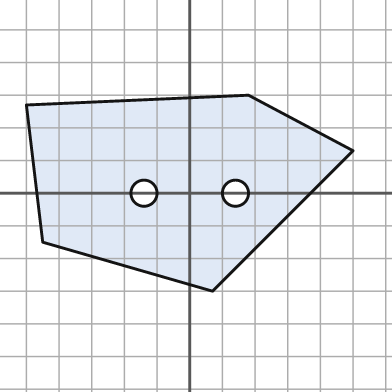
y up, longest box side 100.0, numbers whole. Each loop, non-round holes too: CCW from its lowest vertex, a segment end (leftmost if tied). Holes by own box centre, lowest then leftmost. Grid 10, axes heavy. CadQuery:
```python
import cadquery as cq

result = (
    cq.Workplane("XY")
    .moveTo(7.0, -30.0)
    .lineTo(50.0, 13.0)
    .lineTo(18.0, 30.0)
    .lineTo(-50.0, 27.0)
    .lineTo(-45.0, -15.0)
    .close()
    .moveTo(-14.0, 0.0)
    .circle(4.0)
    .moveTo(14.0, 0.0)
    .circle(4.0)
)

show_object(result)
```